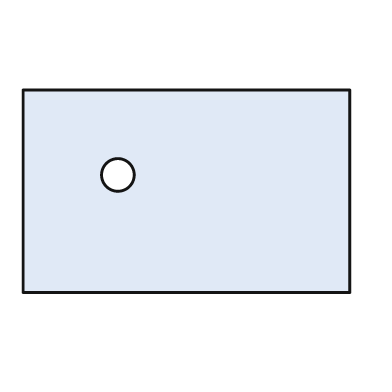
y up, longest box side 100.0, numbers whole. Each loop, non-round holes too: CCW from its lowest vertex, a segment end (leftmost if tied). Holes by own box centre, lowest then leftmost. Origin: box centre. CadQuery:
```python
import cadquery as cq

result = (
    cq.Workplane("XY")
    .moveTo(-50.0, -31.0)
    .lineTo(50.0, -31.0)
    .lineTo(50.0, 31.0)
    .lineTo(-50.0, 31.0)
    .close()
    .moveTo(-21.0, 5.0)
    .circle(5.0)
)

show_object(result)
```